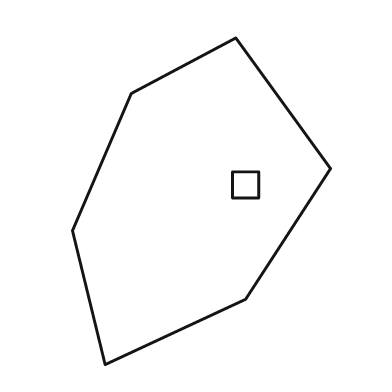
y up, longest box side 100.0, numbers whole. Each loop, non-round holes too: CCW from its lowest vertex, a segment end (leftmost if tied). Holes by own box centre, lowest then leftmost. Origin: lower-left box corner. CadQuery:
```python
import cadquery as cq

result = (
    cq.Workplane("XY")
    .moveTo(10.0, 0.0)
    .lineTo(53.0, 20.0)
    .lineTo(79.0, 60.0)
    .lineTo(50.0, 100.0)
    .lineTo(18.0, 83.0)
    .lineTo(0.0, 41.0)
    .close()
    .moveTo(49.0, 51.0)
    .lineTo(57.0, 51.0)
    .lineTo(57.0, 59.0)
    .lineTo(49.0, 59.0)
    .close()
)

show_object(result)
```